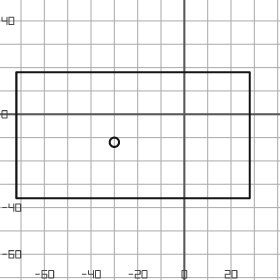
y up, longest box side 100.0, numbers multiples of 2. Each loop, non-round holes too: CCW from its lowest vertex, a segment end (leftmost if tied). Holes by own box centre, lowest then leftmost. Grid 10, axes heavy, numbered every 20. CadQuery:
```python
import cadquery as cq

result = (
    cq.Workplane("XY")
    .moveTo(-72.0, -36.0)
    .lineTo(28.0, -36.0)
    .lineTo(28.0, 18.0)
    .lineTo(-72.0, 18.0)
    .close()
    .moveTo(-30.0, -12.0)
    .circle(2.0)
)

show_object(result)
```